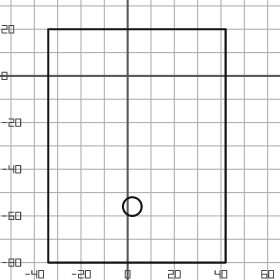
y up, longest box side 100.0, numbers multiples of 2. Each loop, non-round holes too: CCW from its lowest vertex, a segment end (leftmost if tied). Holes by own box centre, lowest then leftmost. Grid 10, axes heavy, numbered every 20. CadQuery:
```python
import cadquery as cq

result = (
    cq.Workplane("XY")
    .moveTo(-34.0, -80.0)
    .lineTo(42.0, -80.0)
    .lineTo(42.0, 20.0)
    .lineTo(-34.0, 20.0)
    .close()
    .moveTo(2.0, -56.0)
    .circle(4.0)
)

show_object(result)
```